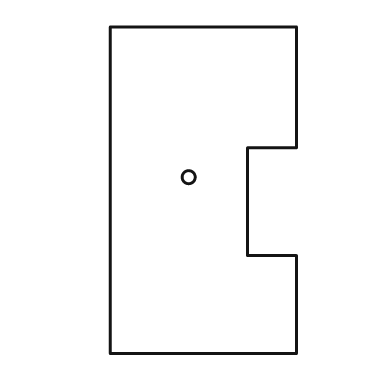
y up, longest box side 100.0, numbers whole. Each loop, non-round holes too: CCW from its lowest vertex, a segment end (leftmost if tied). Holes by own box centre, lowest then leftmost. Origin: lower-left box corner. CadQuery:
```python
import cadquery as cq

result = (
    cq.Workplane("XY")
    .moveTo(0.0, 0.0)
    .lineTo(57.0, 0.0)
    .lineTo(57.0, 30.0)
    .lineTo(42.0, 30.0)
    .lineTo(42.0, 63.0)
    .lineTo(57.0, 63.0)
    .lineTo(57.0, 100.0)
    .lineTo(0.0, 100.0)
    .close()
    .moveTo(24.0, 54.0)
    .circle(2.0)
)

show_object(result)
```